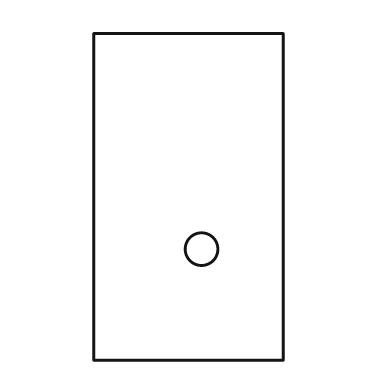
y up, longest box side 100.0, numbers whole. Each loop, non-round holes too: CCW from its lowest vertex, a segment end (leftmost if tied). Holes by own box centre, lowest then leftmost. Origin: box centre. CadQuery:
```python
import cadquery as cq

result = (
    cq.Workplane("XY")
    .moveTo(-29.0, -50.0)
    .lineTo(29.0, -50.0)
    .lineTo(29.0, 50.0)
    .lineTo(-29.0, 50.0)
    .close()
    .moveTo(4.0, -16.0)
    .circle(5.0)
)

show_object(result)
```